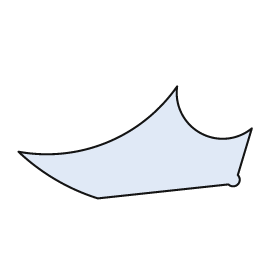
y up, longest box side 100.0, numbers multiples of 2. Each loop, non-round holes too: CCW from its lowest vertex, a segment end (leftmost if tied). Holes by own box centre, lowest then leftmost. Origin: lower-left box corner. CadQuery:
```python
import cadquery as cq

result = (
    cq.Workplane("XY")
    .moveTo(34.0, 0.0)
    .lineTo(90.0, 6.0)
    .threePointArc((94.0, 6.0), (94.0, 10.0))
    .lineTo(100.0, 30.0)
    .threePointArc((78.0, 28.0), (68.0, 48.0))
    .threePointArc((38.0, 24.0), (0.0, 20.0))
    .threePointArc((16.0, 8.0), (34.0, 0.0))
    .close()
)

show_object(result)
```